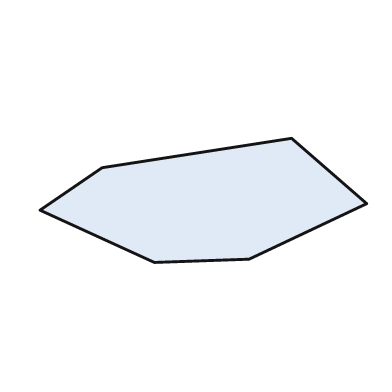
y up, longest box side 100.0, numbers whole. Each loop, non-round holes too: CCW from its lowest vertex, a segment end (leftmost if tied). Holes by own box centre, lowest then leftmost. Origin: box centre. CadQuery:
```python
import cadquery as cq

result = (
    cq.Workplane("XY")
    .moveTo(-15.0, -19.0)
    .lineTo(14.0, -18.0)
    .lineTo(50.0, -1.0)
    .lineTo(27.0, 19.0)
    .lineTo(-31.0, 10.0)
    .lineTo(-50.0, -3.0)
    .close()
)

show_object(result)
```